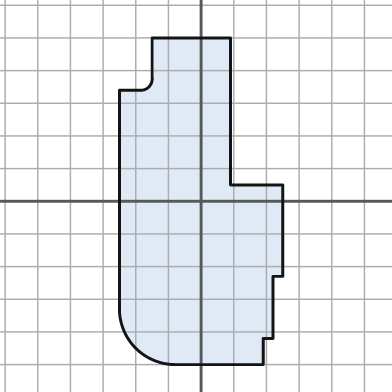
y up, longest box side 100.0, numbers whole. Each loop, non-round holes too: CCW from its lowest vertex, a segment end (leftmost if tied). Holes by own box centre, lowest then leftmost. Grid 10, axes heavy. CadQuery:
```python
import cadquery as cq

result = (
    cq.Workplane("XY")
    .moveTo(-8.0, -50.0)
    .lineTo(19.0, -50.0)
    .lineTo(19.0, -42.0)
    .lineTo(22.0, -42.0)
    .lineTo(22.0, -23.0)
    .lineTo(25.0, -23.0)
    .lineTo(25.0, 5.0)
    .lineTo(9.0, 5.0)
    .lineTo(9.0, 50.0)
    .lineTo(-15.0, 50.0)
    .lineTo(-15.0, 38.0)
    .threePointArc((-16.0, 35.0), (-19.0, 34.0))
    .lineTo(-25.0, 34.0)
    .lineTo(-25.0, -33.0)
    .threePointArc((-20.0, -45.0), (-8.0, -50.0))
    .close()
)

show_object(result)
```